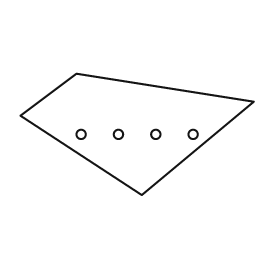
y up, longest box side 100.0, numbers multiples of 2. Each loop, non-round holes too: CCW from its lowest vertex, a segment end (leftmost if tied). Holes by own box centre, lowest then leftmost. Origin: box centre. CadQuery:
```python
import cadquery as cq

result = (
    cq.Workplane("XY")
    .moveTo(2.0, -26.0)
    .lineTo(50.0, 14.0)
    .lineTo(-26.0, 26.0)
    .lineTo(-50.0, 8.0)
    .close()
    .moveTo(-24.0, 0.0)
    .circle(2.0)
    .moveTo(-8.0, 0.0)
    .circle(2.0)
    .moveTo(8.0, 0.0)
    .circle(2.0)
    .moveTo(24.0, 0.0)
    .circle(2.0)
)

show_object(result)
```